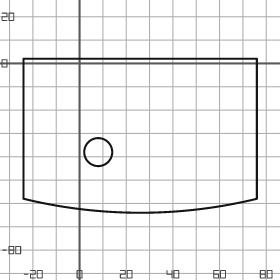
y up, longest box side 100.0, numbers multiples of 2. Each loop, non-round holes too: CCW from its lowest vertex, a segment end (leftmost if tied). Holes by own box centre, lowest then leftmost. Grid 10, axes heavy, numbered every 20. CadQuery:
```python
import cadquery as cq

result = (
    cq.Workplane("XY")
    .moveTo(-24.0, -58.0)
    .threePointArc((26.0, -64.0), (76.0, -58.0))
    .lineTo(76.0, 2.0)
    .lineTo(-24.0, 2.0)
    .close()
    .moveTo(8.0, -38.0)
    .circle(6.0)
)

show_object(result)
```